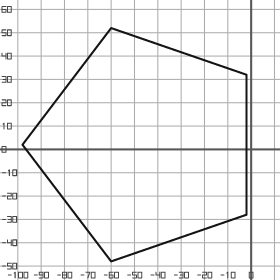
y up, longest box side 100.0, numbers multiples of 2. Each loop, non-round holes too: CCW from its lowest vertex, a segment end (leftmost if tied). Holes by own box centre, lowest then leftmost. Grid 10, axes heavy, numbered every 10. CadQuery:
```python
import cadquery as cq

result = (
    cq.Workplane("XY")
    .moveTo(-60.0, -48.0)
    .lineTo(-2.0, -28.0)
    .lineTo(-2.0, 32.0)
    .lineTo(-60.0, 52.0)
    .lineTo(-98.0, 2.0)
    .close()
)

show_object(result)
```